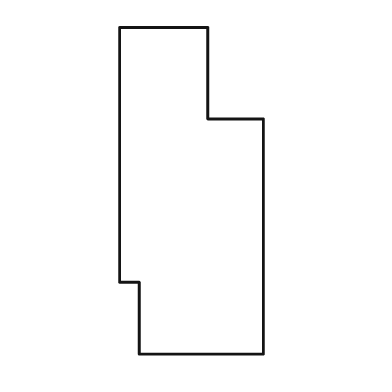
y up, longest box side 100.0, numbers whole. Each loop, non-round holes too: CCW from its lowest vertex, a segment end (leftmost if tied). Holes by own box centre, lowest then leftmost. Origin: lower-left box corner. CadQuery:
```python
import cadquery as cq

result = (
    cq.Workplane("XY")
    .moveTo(6.0, 0.0)
    .lineTo(44.0, 0.0)
    .lineTo(44.0, 72.0)
    .lineTo(27.0, 72.0)
    .lineTo(27.0, 100.0)
    .lineTo(0.0, 100.0)
    .lineTo(0.0, 22.0)
    .lineTo(6.0, 22.0)
    .close()
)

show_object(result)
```